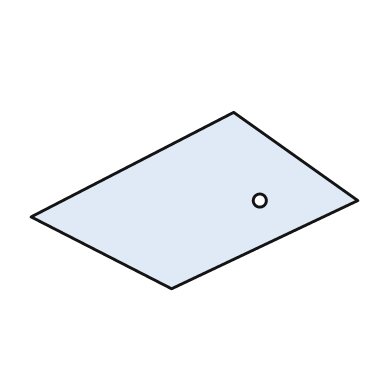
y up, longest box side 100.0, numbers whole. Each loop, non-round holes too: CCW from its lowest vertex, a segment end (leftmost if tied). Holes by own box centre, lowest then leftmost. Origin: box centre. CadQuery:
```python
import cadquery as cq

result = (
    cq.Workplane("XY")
    .moveTo(-7.0, -27.0)
    .lineTo(50.0, 0.0)
    .lineTo(12.0, 27.0)
    .lineTo(-50.0, -5.0)
    .close()
    .moveTo(20.0, 0.0)
    .circle(2.0)
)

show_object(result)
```